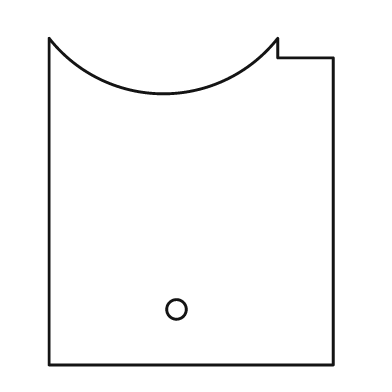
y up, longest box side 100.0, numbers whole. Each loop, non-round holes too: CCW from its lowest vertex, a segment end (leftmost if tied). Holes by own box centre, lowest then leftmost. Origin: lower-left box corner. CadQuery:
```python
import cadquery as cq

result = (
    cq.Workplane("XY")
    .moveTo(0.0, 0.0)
    .lineTo(87.0, 0.0)
    .lineTo(87.0, 94.0)
    .lineTo(70.0, 94.0)
    .lineTo(70.0, 100.0)
    .threePointArc((35.0, 83.0), (0.0, 100.0))
    .close()
    .moveTo(39.0, 17.0)
    .circle(3.0)
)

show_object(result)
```